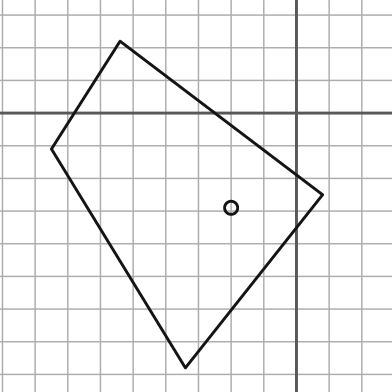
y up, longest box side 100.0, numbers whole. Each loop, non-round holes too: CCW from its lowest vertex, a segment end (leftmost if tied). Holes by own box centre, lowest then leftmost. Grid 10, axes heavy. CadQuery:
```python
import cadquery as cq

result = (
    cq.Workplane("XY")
    .moveTo(-34.0, -78.0)
    .lineTo(8.0, -25.0)
    .lineTo(-54.0, 22.0)
    .lineTo(-75.0, -11.0)
    .close()
    .moveTo(-20.0, -29.0)
    .circle(2.0)
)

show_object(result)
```